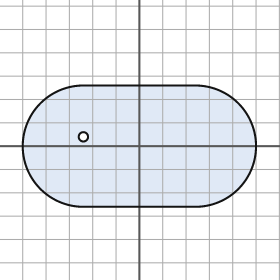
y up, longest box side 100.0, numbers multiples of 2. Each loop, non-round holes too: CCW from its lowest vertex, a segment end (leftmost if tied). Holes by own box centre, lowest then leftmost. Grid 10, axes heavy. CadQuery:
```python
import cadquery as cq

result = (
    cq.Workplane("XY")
    .moveTo(-24.0, -26.0)
    .lineTo(24.0, -26.0)
    .threePointArc((50.0, 0.0), (24.0, 26.0))
    .lineTo(-24.0, 26.0)
    .threePointArc((-50.0, 0.0), (-24.0, -26.0))
    .close()
    .moveTo(-24.0, 4.0)
    .circle(2.0)
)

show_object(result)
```